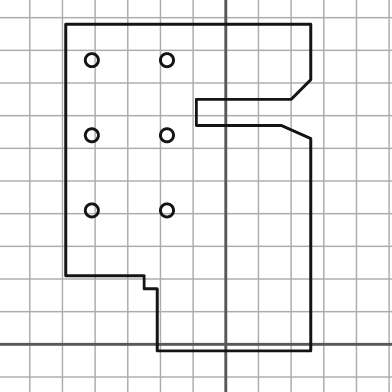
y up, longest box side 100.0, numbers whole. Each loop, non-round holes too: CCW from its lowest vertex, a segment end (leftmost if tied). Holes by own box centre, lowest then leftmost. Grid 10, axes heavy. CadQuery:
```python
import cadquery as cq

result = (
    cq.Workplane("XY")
    .moveTo(-21.0, -2.0)
    .lineTo(26.0, -2.0)
    .lineTo(26.0, 63.0)
    .lineTo(17.0, 67.0)
    .lineTo(-9.0, 67.0)
    .lineTo(-9.0, 75.0)
    .lineTo(20.0, 75.0)
    .lineTo(26.0, 81.0)
    .lineTo(26.0, 98.0)
    .lineTo(-49.0, 98.0)
    .lineTo(-49.0, 21.0)
    .lineTo(-25.0, 21.0)
    .lineTo(-25.0, 17.0)
    .lineTo(-21.0, 17.0)
    .close()
    .moveTo(-41.0, 41.0)
    .circle(2.0)
    .moveTo(-18.0, 41.0)
    .circle(2.0)
    .moveTo(-41.0, 64.0)
    .circle(2.0)
    .moveTo(-18.0, 64.0)
    .circle(2.0)
    .moveTo(-41.0, 87.0)
    .circle(2.0)
    .moveTo(-18.0, 87.0)
    .circle(2.0)
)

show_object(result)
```